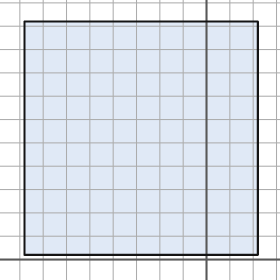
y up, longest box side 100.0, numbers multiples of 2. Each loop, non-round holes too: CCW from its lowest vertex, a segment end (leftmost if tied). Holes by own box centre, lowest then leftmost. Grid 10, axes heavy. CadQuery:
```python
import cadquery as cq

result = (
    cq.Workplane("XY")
    .moveTo(-78.0, 2.0)
    .lineTo(22.0, 2.0)
    .lineTo(22.0, 102.0)
    .lineTo(-78.0, 102.0)
    .close()
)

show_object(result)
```